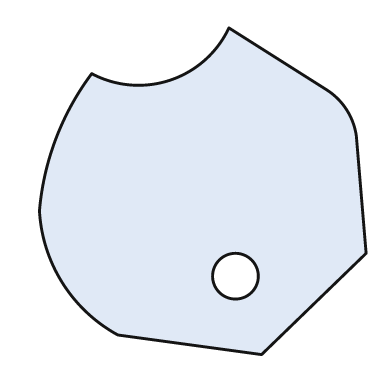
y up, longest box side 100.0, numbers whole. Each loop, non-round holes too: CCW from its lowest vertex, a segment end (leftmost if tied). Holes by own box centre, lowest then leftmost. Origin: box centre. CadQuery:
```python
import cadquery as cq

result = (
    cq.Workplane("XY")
    .moveTo(18.0, -50.0)
    .lineTo(50.0, -19.0)
    .lineTo(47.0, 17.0)
    .threePointArc((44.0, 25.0), (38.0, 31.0))
    .lineTo(8.0, 50.0)
    .threePointArc((-10.0, 34.0), (-34.0, 36.0))
    .threePointArc((-45.0, 16.0), (-50.0, -6.0))
    .threePointArc((-43.0, -28.0), (-26.0, -44.0))
    .close()
    .moveTo(10.0, -26.0)
    .circle(7.0)
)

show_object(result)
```